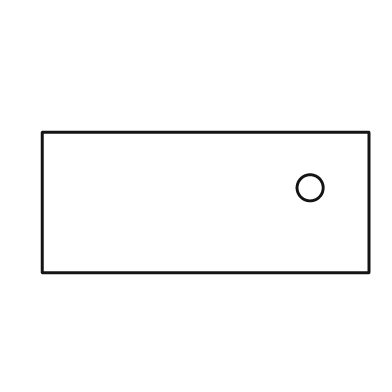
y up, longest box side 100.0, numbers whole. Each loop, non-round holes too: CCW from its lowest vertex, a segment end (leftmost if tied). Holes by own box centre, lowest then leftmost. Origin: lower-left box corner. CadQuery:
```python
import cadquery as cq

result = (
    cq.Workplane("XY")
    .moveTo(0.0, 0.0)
    .lineTo(100.0, 0.0)
    .lineTo(100.0, 43.0)
    .lineTo(0.0, 43.0)
    .close()
    .moveTo(82.0, 26.0)
    .circle(4.0)
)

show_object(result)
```